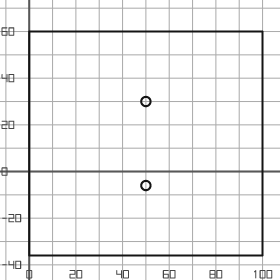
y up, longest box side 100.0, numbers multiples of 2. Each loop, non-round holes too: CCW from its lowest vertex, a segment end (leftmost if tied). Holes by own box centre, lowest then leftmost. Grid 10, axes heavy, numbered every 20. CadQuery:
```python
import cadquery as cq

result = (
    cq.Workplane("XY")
    .moveTo(0.0, -36.0)
    .lineTo(100.0, -36.0)
    .lineTo(100.0, 60.0)
    .lineTo(0.0, 60.0)
    .close()
    .moveTo(50.0, -6.0)
    .circle(2.0)
    .moveTo(50.0, 30.0)
    .circle(2.0)
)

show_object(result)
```